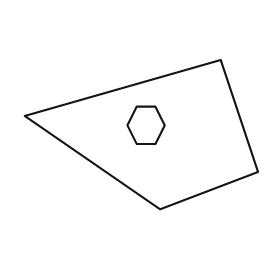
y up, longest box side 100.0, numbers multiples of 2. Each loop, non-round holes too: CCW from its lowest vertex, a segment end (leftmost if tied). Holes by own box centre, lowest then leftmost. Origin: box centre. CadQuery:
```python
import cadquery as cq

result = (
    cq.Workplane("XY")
    .moveTo(8.0, -32.0)
    .lineTo(50.0, -16.0)
    .lineTo(34.0, 32.0)
    .lineTo(-50.0, 8.0)
    .close()
    .moveTo(-2.0, -4.0)
    .lineTo(6.0, -4.0)
    .lineTo(10.0, 4.0)
    .lineTo(6.0, 12.0)
    .lineTo(-2.0, 12.0)
    .lineTo(-6.0, 4.0)
    .close()
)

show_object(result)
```